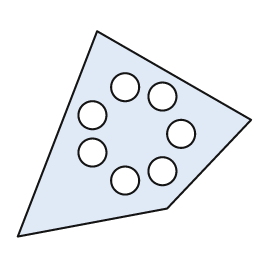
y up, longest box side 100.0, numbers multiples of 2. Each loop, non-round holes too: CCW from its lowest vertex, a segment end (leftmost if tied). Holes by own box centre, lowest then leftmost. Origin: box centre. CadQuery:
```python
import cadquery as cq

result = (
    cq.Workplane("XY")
    .moveTo(-50.0, -44.0)
    .lineTo(14.0, -32.0)
    .lineTo(50.0, 6.0)
    .lineTo(-16.0, 44.0)
    .close()
    .moveTo(-4.0, -20.0)
    .circle(6.0)
    .moveTo(12.0, -16.0)
    .circle(6.0)
    .moveTo(-18.0, -8.0)
    .circle(6.0)
    .moveTo(20.0, 0.0)
    .circle(6.0)
    .moveTo(-18.0, 8.0)
    .circle(6.0)
    .moveTo(12.0, 16.0)
    .circle(6.0)
    .moveTo(-4.0, 20.0)
    .circle(6.0)
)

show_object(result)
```